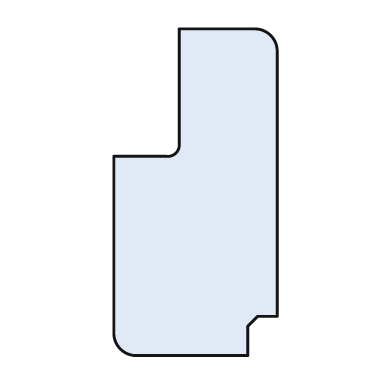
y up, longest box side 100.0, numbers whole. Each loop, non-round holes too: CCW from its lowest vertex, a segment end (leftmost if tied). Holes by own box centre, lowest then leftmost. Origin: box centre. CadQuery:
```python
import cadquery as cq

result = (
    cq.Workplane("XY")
    .moveTo(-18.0, -50.0)
    .lineTo(16.0, -50.0)
    .lineTo(16.0, -41.0)
    .lineTo(19.0, -38.0)
    .lineTo(25.0, -38.0)
    .lineTo(25.0, 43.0)
    .threePointArc((23.0, 48.0), (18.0, 50.0))
    .lineTo(-5.0, 50.0)
    .lineTo(-5.0, 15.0)
    .threePointArc((-6.0, 12.0), (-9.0, 11.0))
    .lineTo(-25.0, 11.0)
    .lineTo(-25.0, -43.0)
    .threePointArc((-23.0, -48.0), (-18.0, -50.0))
    .close()
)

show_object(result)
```